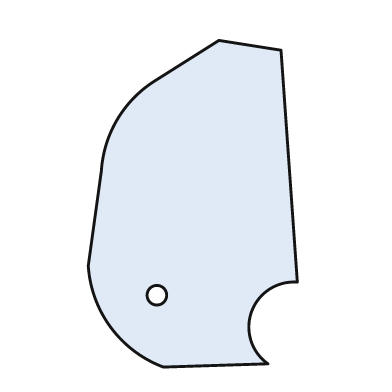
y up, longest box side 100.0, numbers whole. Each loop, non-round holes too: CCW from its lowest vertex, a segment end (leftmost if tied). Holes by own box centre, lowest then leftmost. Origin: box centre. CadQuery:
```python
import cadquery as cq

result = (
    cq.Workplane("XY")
    .moveTo(-9.0, -50.0)
    .lineTo(23.0, -49.0)
    .threePointArc((18.0, -33.0), (32.0, -24.0))
    .lineTo(27.0, 47.0)
    .lineTo(8.0, 50.0)
    .lineTo(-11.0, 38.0)
    .threePointArc((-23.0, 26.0), (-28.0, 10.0))
    .lineTo(-32.0, -19.0)
    .threePointArc((-25.0, -38.0), (-9.0, -50.0))
    .close()
    .moveTo(-11.0, -28.0)
    .circle(3.0)
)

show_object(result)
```